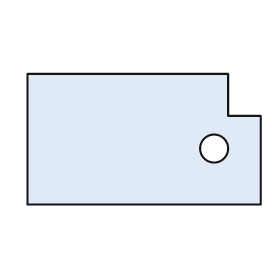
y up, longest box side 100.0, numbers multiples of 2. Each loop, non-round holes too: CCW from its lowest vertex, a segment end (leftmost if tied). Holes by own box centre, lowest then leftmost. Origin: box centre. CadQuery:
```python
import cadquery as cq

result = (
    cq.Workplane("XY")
    .moveTo(-50.0, -28.0)
    .lineTo(50.0, -28.0)
    .lineTo(50.0, 10.0)
    .lineTo(36.0, 10.0)
    .lineTo(36.0, 28.0)
    .lineTo(-50.0, 28.0)
    .close()
    .moveTo(30.0, -4.0)
    .circle(6.0)
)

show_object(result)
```